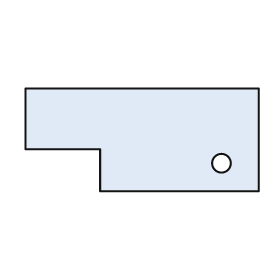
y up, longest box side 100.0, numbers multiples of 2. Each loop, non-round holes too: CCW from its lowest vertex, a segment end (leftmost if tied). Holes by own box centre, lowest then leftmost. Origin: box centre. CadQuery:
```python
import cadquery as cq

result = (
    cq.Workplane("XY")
    .moveTo(-18.0, -22.0)
    .lineTo(50.0, -22.0)
    .lineTo(50.0, 22.0)
    .lineTo(-50.0, 22.0)
    .lineTo(-50.0, -4.0)
    .lineTo(-18.0, -4.0)
    .close()
    .moveTo(34.0, -10.0)
    .circle(4.0)
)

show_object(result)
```